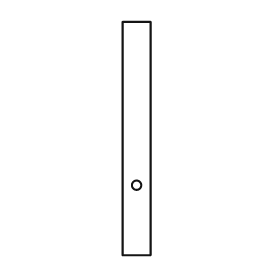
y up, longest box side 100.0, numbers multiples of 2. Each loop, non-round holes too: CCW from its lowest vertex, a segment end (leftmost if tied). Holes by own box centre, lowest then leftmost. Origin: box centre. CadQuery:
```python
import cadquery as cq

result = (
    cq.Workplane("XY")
    .moveTo(-6.0, -50.0)
    .lineTo(6.0, -50.0)
    .lineTo(6.0, 50.0)
    .lineTo(-6.0, 50.0)
    .close()
    .moveTo(0.0, -20.0)
    .circle(2.0)
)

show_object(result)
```